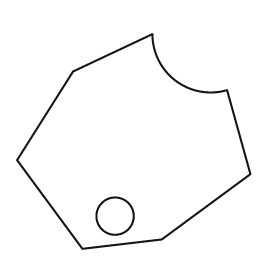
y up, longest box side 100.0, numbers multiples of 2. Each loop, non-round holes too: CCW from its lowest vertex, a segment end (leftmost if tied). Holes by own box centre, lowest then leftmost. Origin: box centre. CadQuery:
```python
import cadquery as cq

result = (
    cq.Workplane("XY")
    .moveTo(-22.0, -46.0)
    .lineTo(12.0, -42.0)
    .lineTo(50.0, -14.0)
    .lineTo(40.0, 22.0)
    .threePointArc((18.0, 26.0), (8.0, 46.0))
    .lineTo(-26.0, 30.0)
    .lineTo(-50.0, -8.0)
    .close()
    .moveTo(-8.0, -32.0)
    .circle(8.0)
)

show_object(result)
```